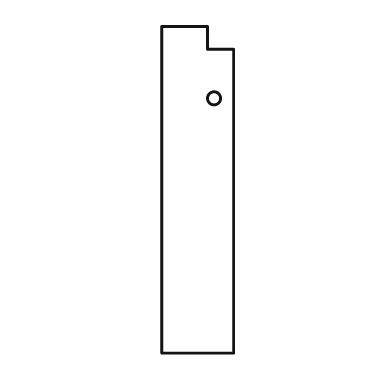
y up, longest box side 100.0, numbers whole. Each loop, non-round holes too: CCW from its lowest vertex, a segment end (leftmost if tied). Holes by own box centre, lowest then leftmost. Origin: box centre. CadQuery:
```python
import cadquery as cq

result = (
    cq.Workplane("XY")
    .moveTo(-11.0, -50.0)
    .lineTo(11.0, -50.0)
    .lineTo(11.0, 43.0)
    .lineTo(3.0, 43.0)
    .lineTo(3.0, 50.0)
    .lineTo(-11.0, 50.0)
    .close()
    .moveTo(5.0, 28.0)
    .circle(2.0)
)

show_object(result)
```